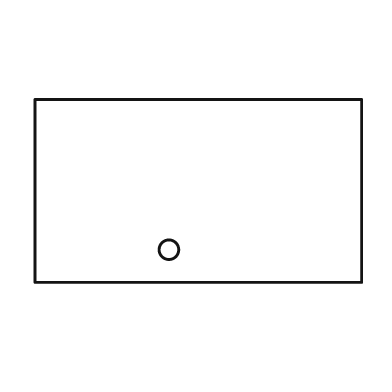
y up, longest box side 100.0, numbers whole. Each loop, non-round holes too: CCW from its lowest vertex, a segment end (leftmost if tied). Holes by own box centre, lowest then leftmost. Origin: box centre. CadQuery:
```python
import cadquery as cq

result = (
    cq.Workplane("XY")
    .moveTo(-50.0, -28.0)
    .lineTo(50.0, -28.0)
    .lineTo(50.0, 28.0)
    .lineTo(-50.0, 28.0)
    .close()
    .moveTo(-9.0, -18.0)
    .circle(3.0)
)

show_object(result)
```